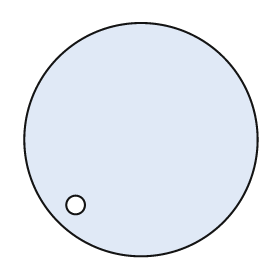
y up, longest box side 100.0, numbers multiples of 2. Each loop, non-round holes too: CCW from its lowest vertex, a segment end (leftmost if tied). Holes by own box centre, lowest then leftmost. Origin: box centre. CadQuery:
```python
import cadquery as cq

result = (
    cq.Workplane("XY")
    .moveTo(0.0, 0.0)
    .circle(50.0)
    .moveTo(-28.0, -28.0)
    .circle(4.0)
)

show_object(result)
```